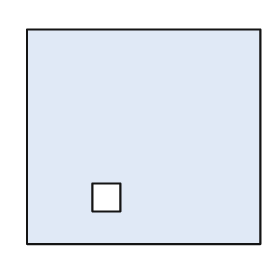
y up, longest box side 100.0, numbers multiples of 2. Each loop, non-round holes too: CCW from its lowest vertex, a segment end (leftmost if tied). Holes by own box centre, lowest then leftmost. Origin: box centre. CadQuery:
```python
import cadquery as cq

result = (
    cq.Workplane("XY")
    .moveTo(-50.0, -46.0)
    .lineTo(50.0, -46.0)
    .lineTo(50.0, 46.0)
    .lineTo(-50.0, 46.0)
    .close()
    .moveTo(-22.0, -32.0)
    .lineTo(-10.0, -32.0)
    .lineTo(-10.0, -20.0)
    .lineTo(-22.0, -20.0)
    .close()
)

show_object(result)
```